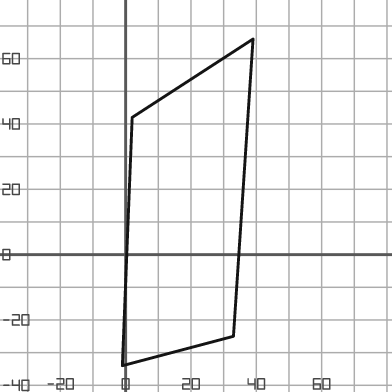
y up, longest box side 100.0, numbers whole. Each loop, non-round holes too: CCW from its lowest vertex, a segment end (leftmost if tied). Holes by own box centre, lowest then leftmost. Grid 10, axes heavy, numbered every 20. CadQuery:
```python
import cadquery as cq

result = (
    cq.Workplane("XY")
    .moveTo(-1.0, -34.0)
    .lineTo(33.0, -25.0)
    .lineTo(39.0, 66.0)
    .lineTo(2.0, 42.0)
    .close()
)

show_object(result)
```